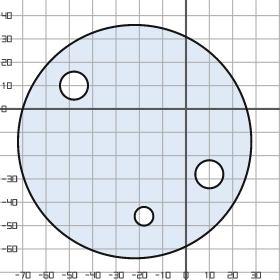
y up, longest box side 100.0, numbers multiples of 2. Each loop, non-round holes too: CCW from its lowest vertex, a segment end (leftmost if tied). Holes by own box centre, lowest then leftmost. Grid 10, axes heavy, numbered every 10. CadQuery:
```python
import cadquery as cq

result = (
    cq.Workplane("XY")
    .moveTo(-22.0, -14.0)
    .circle(50.0)
    .moveTo(-18.0, -46.0)
    .circle(4.0)
    .moveTo(10.0, -28.0)
    .circle(6.0)
    .moveTo(-48.0, 10.0)
    .circle(6.0)
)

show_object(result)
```